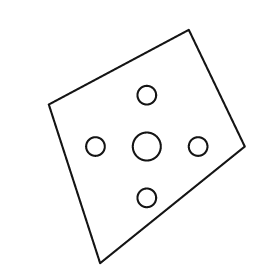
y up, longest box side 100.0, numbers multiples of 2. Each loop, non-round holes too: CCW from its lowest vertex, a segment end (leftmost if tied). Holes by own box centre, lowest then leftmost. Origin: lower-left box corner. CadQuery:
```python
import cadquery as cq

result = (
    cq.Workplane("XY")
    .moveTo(22.0, 0.0)
    .lineTo(84.0, 50.0)
    .lineTo(60.0, 100.0)
    .lineTo(0.0, 68.0)
    .close()
    .moveTo(42.0, 28.0)
    .circle(4.0)
    .moveTo(20.0, 50.0)
    .circle(4.0)
    .moveTo(42.0, 50.0)
    .circle(6.0)
    .moveTo(64.0, 50.0)
    .circle(4.0)
    .moveTo(42.0, 72.0)
    .circle(4.0)
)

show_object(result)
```